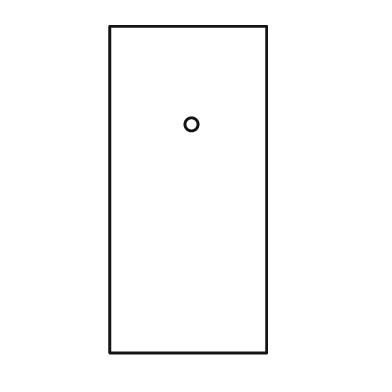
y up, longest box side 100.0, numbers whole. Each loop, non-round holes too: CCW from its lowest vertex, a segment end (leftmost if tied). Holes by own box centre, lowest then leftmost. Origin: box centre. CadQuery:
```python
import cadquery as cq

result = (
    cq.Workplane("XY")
    .moveTo(-24.0, -50.0)
    .lineTo(24.0, -50.0)
    .lineTo(24.0, 50.0)
    .lineTo(-24.0, 50.0)
    .close()
    .moveTo(1.0, 20.0)
    .circle(2.0)
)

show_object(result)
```